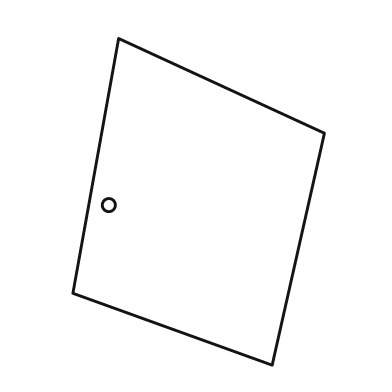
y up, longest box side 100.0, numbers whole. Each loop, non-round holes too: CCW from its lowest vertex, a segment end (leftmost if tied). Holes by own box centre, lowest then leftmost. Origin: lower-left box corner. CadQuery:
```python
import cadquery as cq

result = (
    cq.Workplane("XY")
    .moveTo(61.0, 0.0)
    .lineTo(77.0, 71.0)
    .lineTo(14.0, 100.0)
    .lineTo(0.0, 22.0)
    .close()
    .moveTo(11.0, 49.0)
    .circle(2.0)
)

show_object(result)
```